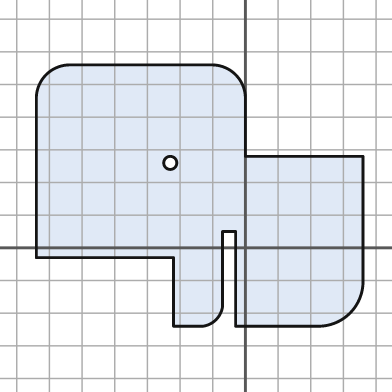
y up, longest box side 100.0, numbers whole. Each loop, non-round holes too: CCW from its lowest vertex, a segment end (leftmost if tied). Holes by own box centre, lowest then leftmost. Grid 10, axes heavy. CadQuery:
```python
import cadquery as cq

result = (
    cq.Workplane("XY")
    .moveTo(-22.0, -24.0)
    .lineTo(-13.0, -24.0)
    .threePointArc((-9.0, -22.0), (-7.0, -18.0))
    .lineTo(-7.0, 5.0)
    .lineTo(-3.0, 5.0)
    .lineTo(-3.0, -24.0)
    .lineTo(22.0, -24.0)
    .threePointArc((32.0, -20.0), (36.0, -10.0))
    .lineTo(36.0, 28.0)
    .lineTo(0.0, 28.0)
    .lineTo(0.0, 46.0)
    .threePointArc((-3.0, 53.0), (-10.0, 56.0))
    .lineTo(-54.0, 56.0)
    .threePointArc((-61.0, 53.0), (-64.0, 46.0))
    .lineTo(-64.0, -3.0)
    .lineTo(-22.0, -3.0)
    .close()
    .moveTo(-23.0, 26.0)
    .circle(2.0)
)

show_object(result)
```